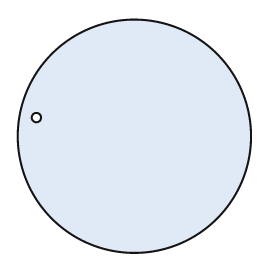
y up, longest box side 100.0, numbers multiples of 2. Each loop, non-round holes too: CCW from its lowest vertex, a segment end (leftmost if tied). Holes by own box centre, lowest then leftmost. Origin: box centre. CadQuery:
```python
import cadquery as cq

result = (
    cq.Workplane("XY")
    .moveTo(0.0, 0.0)
    .circle(50.0)
    .moveTo(-42.0, 8.0)
    .circle(2.0)
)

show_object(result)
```